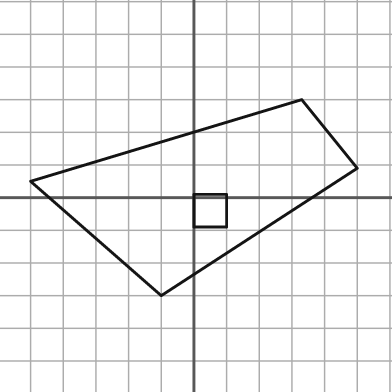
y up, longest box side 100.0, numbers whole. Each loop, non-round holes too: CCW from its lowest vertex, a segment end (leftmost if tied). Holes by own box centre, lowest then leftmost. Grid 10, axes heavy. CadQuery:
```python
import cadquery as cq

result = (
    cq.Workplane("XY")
    .moveTo(-10.0, -30.0)
    .lineTo(50.0, 9.0)
    .lineTo(33.0, 30.0)
    .lineTo(-50.0, 5.0)
    .close()
    .moveTo(0.0, -9.0)
    .lineTo(10.0, -9.0)
    .lineTo(10.0, 1.0)
    .lineTo(0.0, 1.0)
    .close()
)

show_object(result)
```